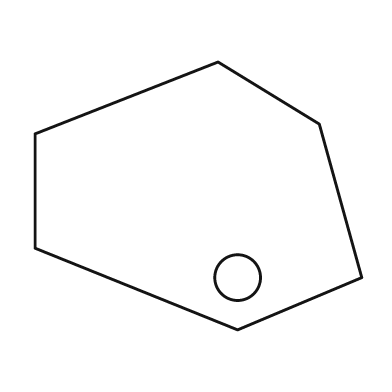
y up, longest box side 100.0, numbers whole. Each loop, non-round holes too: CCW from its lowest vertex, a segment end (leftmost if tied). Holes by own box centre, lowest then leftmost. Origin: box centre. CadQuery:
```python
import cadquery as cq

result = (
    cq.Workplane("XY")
    .moveTo(12.0, -41.0)
    .lineTo(50.0, -25.0)
    .lineTo(37.0, 22.0)
    .lineTo(6.0, 41.0)
    .lineTo(-50.0, 19.0)
    .lineTo(-50.0, -16.0)
    .close()
    .moveTo(12.0, -25.0)
    .circle(7.0)
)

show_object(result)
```